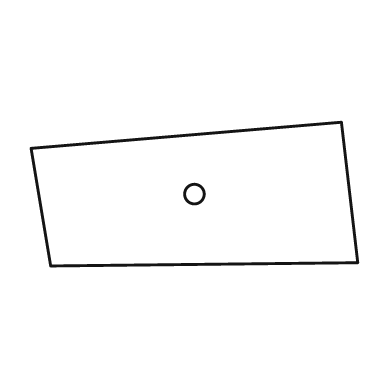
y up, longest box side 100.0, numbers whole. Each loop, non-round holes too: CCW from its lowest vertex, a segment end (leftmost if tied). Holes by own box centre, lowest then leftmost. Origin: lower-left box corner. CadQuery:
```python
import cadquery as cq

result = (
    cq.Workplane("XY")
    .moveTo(6.0, 0.0)
    .lineTo(100.0, 1.0)
    .lineTo(95.0, 44.0)
    .lineTo(0.0, 36.0)
    .close()
    .moveTo(50.0, 22.0)
    .circle(3.0)
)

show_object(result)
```